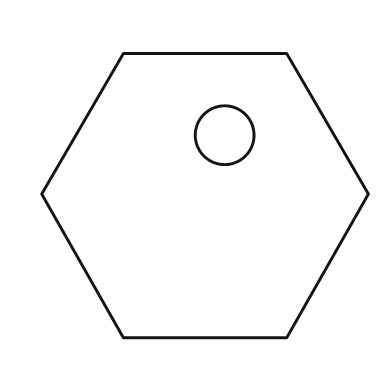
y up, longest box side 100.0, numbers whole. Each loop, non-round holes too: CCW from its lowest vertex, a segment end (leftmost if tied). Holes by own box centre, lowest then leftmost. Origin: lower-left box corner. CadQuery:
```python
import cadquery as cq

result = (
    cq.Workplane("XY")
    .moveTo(25.0, 0.0)
    .lineTo(75.0, 0.0)
    .lineTo(100.0, 44.0)
    .lineTo(75.0, 87.0)
    .lineTo(25.0, 87.0)
    .lineTo(0.0, 44.0)
    .close()
    .moveTo(56.0, 62.0)
    .circle(9.0)
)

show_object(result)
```